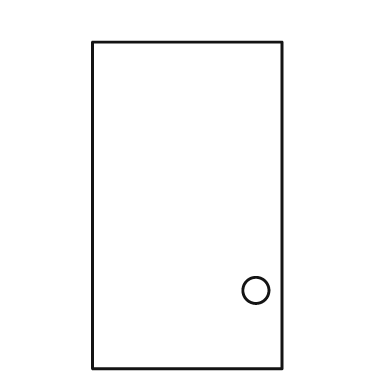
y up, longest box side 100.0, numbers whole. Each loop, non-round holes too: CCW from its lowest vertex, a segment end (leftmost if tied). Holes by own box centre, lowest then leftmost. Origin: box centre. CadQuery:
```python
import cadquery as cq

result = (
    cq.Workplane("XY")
    .moveTo(-29.0, -50.0)
    .lineTo(29.0, -50.0)
    .lineTo(29.0, 50.0)
    .lineTo(-29.0, 50.0)
    .close()
    .moveTo(21.0, -26.0)
    .circle(4.0)
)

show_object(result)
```